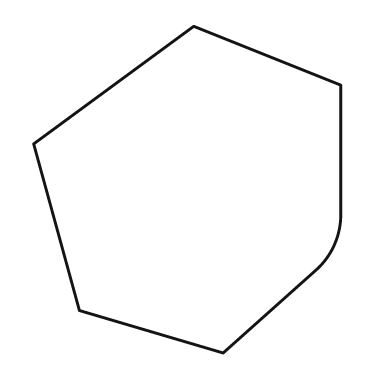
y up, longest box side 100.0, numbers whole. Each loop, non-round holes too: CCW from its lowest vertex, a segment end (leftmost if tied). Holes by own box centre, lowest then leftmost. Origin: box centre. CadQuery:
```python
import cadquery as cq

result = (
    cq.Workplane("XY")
    .moveTo(11.0, -50.0)
    .lineTo(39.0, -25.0)
    .threePointArc((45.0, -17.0), (47.0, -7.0))
    .lineTo(47.0, 32.0)
    .lineTo(2.0, 50.0)
    .lineTo(-47.0, 14.0)
    .lineTo(-33.0, -37.0)
    .close()
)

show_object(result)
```